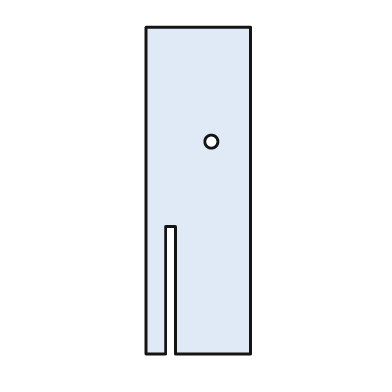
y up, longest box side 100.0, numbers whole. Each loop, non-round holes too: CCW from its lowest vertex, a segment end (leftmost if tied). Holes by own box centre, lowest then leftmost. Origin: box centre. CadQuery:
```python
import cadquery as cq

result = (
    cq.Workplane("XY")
    .moveTo(-16.0, -50.0)
    .lineTo(-10.0, -50.0)
    .lineTo(-10.0, -11.0)
    .lineTo(-7.0, -11.0)
    .lineTo(-7.0, -50.0)
    .lineTo(16.0, -50.0)
    .lineTo(16.0, 50.0)
    .lineTo(-16.0, 50.0)
    .close()
    .moveTo(4.0, 15.0)
    .circle(2.0)
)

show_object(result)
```